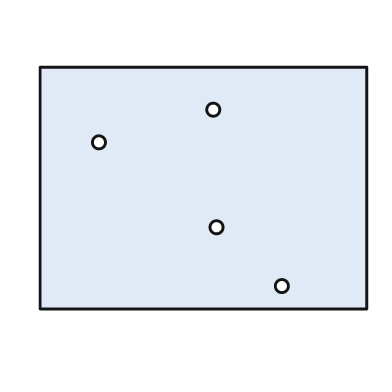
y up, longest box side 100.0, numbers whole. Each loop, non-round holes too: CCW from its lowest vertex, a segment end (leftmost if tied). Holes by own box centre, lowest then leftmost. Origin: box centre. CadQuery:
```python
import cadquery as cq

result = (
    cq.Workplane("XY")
    .moveTo(-50.0, -37.0)
    .lineTo(50.0, -37.0)
    .lineTo(50.0, 37.0)
    .lineTo(-50.0, 37.0)
    .close()
    .moveTo(24.0, -30.0)
    .circle(2.0)
    .moveTo(4.0, -12.0)
    .circle(2.0)
    .moveTo(-32.0, 14.0)
    .circle(2.0)
    .moveTo(3.0, 24.0)
    .circle(2.0)
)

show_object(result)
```